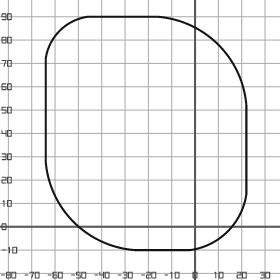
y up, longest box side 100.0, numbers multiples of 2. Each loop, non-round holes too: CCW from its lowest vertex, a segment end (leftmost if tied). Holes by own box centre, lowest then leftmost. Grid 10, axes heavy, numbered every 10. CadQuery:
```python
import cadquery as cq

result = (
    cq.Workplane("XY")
    .moveTo(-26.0, -10.0)
    .lineTo(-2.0, -10.0)
    .threePointArc((14.0, -2.0), (22.0, 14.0))
    .lineTo(22.0, 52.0)
    .threePointArc((10.0, 78.0), (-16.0, 90.0))
    .lineTo(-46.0, 90.0)
    .threePointArc((-58.0, 84.0), (-64.0, 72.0))
    .lineTo(-64.0, 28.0)
    .threePointArc((-52.0, 2.0), (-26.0, -10.0))
    .close()
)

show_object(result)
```